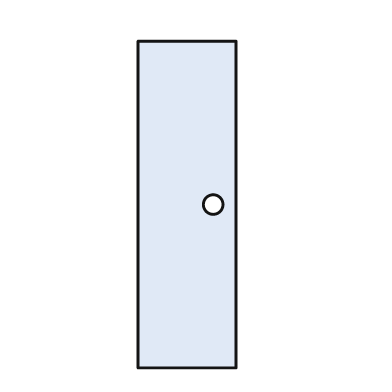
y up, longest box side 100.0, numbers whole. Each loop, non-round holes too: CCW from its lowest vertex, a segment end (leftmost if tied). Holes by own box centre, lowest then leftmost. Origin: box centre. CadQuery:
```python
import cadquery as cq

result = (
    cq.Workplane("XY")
    .moveTo(-15.0, -50.0)
    .lineTo(15.0, -50.0)
    .lineTo(15.0, 50.0)
    .lineTo(-15.0, 50.0)
    .close()
    .moveTo(8.0, 0.0)
    .circle(3.0)
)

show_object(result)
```